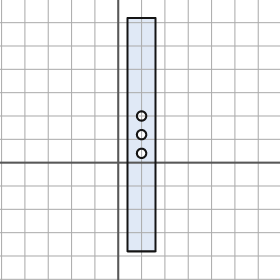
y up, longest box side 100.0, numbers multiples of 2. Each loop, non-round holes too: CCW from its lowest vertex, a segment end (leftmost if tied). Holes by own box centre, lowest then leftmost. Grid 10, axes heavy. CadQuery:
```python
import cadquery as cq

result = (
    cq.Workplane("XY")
    .moveTo(4.0, -38.0)
    .lineTo(16.0, -38.0)
    .lineTo(16.0, 62.0)
    .lineTo(4.0, 62.0)
    .close()
    .moveTo(10.0, 4.0)
    .circle(2.0)
    .moveTo(10.0, 12.0)
    .circle(2.0)
    .moveTo(10.0, 20.0)
    .circle(2.0)
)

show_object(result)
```